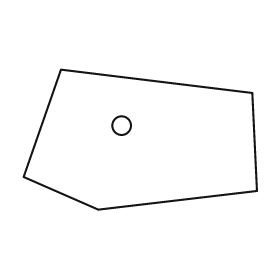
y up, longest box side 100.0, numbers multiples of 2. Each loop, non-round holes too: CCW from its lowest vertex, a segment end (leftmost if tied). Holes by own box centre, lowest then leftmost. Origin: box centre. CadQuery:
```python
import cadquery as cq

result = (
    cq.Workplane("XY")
    .moveTo(-18.0, -30.0)
    .lineTo(50.0, -22.0)
    .lineTo(48.0, 20.0)
    .lineTo(-34.0, 30.0)
    .lineTo(-50.0, -16.0)
    .close()
    .moveTo(-8.0, 6.0)
    .circle(4.0)
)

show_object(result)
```